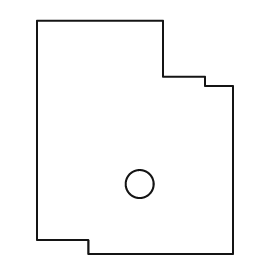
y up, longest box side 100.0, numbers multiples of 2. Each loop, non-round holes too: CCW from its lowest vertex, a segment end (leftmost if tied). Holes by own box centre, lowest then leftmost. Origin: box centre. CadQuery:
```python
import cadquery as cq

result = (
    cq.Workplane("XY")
    .moveTo(-20.0, -50.0)
    .lineTo(42.0, -50.0)
    .lineTo(42.0, 22.0)
    .lineTo(30.0, 22.0)
    .lineTo(30.0, 26.0)
    .lineTo(12.0, 26.0)
    .lineTo(12.0, 50.0)
    .lineTo(-42.0, 50.0)
    .lineTo(-42.0, -44.0)
    .lineTo(-20.0, -44.0)
    .close()
    .moveTo(2.0, -20.0)
    .circle(6.0)
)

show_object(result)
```